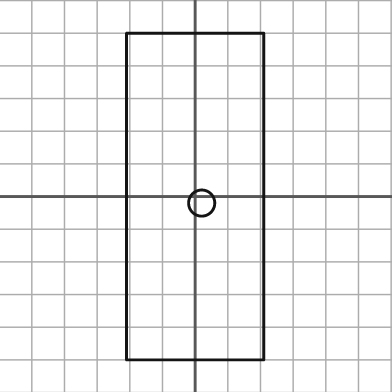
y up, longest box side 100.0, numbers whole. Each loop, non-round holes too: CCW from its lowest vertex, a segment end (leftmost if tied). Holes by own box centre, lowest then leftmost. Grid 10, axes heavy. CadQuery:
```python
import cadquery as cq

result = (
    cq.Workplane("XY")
    .moveTo(-21.0, -50.0)
    .lineTo(21.0, -50.0)
    .lineTo(21.0, 50.0)
    .lineTo(-21.0, 50.0)
    .close()
    .moveTo(2.0, -2.0)
    .circle(4.0)
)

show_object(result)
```